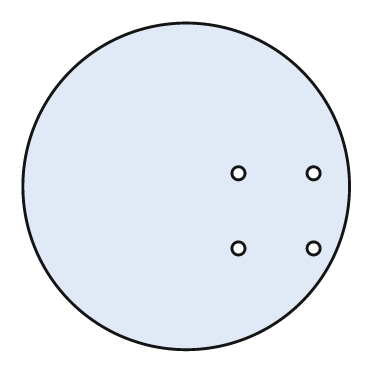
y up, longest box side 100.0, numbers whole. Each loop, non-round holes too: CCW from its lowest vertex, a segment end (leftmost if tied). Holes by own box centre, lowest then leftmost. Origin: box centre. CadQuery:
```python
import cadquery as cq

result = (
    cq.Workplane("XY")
    .moveTo(0.0, 0.0)
    .circle(50.0)
    .moveTo(16.0, -19.0)
    .circle(2.0)
    .moveTo(39.0, -19.0)
    .circle(2.0)
    .moveTo(16.0, 4.0)
    .circle(2.0)
    .moveTo(39.0, 4.0)
    .circle(2.0)
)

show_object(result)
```